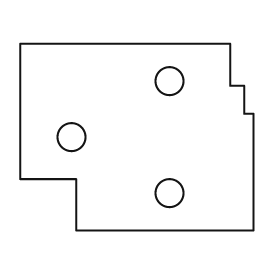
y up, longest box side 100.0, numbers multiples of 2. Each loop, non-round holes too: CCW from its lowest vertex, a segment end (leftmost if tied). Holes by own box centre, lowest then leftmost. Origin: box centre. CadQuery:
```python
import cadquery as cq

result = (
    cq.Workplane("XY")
    .moveTo(-26.0, -40.0)
    .lineTo(50.0, -40.0)
    .lineTo(50.0, 10.0)
    .lineTo(46.0, 10.0)
    .lineTo(46.0, 22.0)
    .lineTo(40.0, 22.0)
    .lineTo(40.0, 40.0)
    .lineTo(-50.0, 40.0)
    .lineTo(-50.0, -18.0)
    .lineTo(-26.0, -18.0)
    .close()
    .moveTo(14.0, -24.0)
    .circle(6.0)
    .moveTo(-28.0, 0.0)
    .circle(6.0)
    .moveTo(14.0, 24.0)
    .circle(6.0)
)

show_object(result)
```